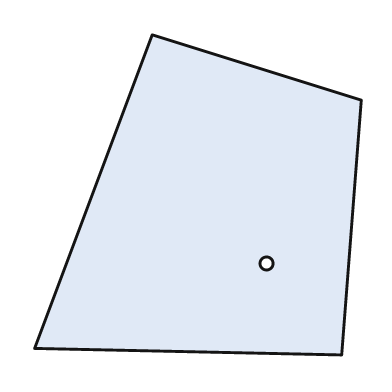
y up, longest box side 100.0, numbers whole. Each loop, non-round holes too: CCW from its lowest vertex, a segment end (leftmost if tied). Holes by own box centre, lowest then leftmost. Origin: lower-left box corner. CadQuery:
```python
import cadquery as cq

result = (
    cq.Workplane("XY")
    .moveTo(94.0, 0.0)
    .lineTo(100.0, 78.0)
    .lineTo(36.0, 98.0)
    .lineTo(0.0, 2.0)
    .close()
    .moveTo(71.0, 28.0)
    .circle(2.0)
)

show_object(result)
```